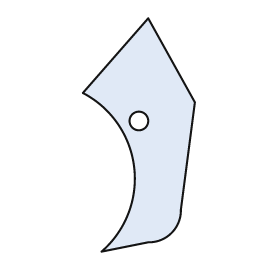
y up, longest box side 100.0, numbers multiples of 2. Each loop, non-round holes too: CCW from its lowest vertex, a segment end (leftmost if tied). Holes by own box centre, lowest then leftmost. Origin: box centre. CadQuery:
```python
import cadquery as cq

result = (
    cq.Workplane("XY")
    .moveTo(-16.0, -50.0)
    .lineTo(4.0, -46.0)
    .threePointArc((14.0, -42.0), (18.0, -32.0))
    .lineTo(24.0, 14.0)
    .lineTo(4.0, 50.0)
    .lineTo(-24.0, 18.0)
    .threePointArc((-2.0, -14.0), (-16.0, -50.0))
    .close()
    .moveTo(0.0, 6.0)
    .circle(4.0)
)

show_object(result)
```